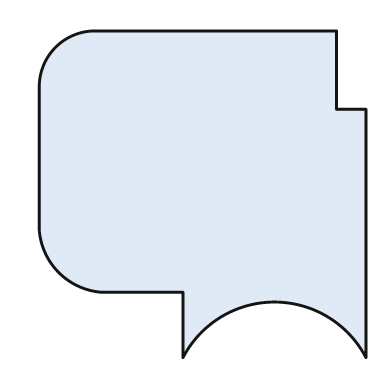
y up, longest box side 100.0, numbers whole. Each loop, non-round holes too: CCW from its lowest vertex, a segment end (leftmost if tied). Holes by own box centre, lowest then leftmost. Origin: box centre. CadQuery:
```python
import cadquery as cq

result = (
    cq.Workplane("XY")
    .moveTo(-6.0, -50.0)
    .threePointArc((22.0, -33.0), (50.0, -50.0))
    .lineTo(50.0, 26.0)
    .lineTo(41.0, 26.0)
    .lineTo(41.0, 50.0)
    .lineTo(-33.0, 50.0)
    .threePointArc((-45.0, 45.0), (-50.0, 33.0))
    .lineTo(-50.0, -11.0)
    .threePointArc((-44.0, -24.0), (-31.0, -30.0))
    .lineTo(-6.0, -30.0)
    .close()
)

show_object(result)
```